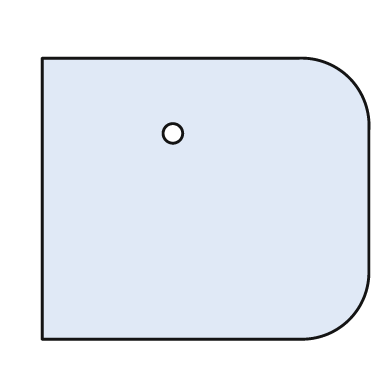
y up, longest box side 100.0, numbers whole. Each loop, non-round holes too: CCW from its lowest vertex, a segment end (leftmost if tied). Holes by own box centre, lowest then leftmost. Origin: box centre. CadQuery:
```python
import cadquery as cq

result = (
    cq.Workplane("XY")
    .moveTo(-50.0, -43.0)
    .lineTo(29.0, -43.0)
    .threePointArc((44.0, -37.0), (50.0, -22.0))
    .lineTo(50.0, 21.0)
    .threePointArc((44.0, 37.0), (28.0, 43.0))
    .lineTo(-50.0, 43.0)
    .close()
    .moveTo(-10.0, 20.0)
    .circle(3.0)
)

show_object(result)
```